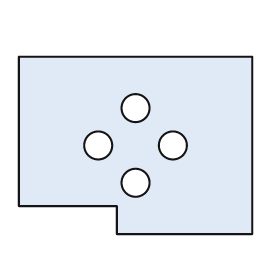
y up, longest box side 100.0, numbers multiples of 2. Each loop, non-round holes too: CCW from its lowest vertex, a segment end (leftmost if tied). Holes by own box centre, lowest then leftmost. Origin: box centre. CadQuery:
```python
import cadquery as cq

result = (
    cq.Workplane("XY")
    .moveTo(-8.0, -38.0)
    .lineTo(50.0, -38.0)
    .lineTo(50.0, 38.0)
    .lineTo(-50.0, 38.0)
    .lineTo(-50.0, -26.0)
    .lineTo(-8.0, -26.0)
    .close()
    .moveTo(0.0, -16.0)
    .circle(6.0)
    .moveTo(-16.0, 0.0)
    .circle(6.0)
    .moveTo(16.0, 0.0)
    .circle(6.0)
    .moveTo(0.0, 16.0)
    .circle(6.0)
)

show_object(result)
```